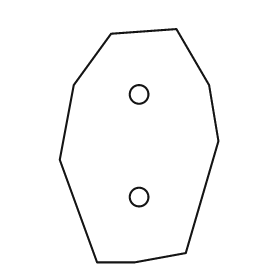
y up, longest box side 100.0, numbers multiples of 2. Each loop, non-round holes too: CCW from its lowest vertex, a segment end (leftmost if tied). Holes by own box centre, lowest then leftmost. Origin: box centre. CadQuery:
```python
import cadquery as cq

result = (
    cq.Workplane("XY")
    .moveTo(-18.0, -50.0)
    .lineTo(-2.0, -50.0)
    .lineTo(20.0, -46.0)
    .lineTo(34.0, 2.0)
    .lineTo(30.0, 26.0)
    .lineTo(16.0, 50.0)
    .lineTo(-12.0, 48.0)
    .lineTo(-28.0, 26.0)
    .lineTo(-34.0, -6.0)
    .close()
    .moveTo(0.0, -22.0)
    .circle(4.0)
    .moveTo(0.0, 22.0)
    .circle(4.0)
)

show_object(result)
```